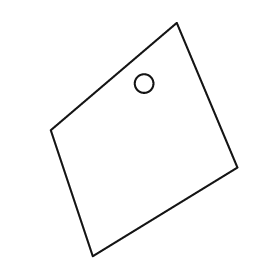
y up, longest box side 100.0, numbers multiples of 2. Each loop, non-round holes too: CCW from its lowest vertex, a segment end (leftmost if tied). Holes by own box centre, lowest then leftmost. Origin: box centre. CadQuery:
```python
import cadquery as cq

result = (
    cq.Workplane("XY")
    .moveTo(-22.0, -50.0)
    .lineTo(40.0, -12.0)
    .lineTo(14.0, 50.0)
    .lineTo(-40.0, 4.0)
    .close()
    .moveTo(0.0, 24.0)
    .circle(4.0)
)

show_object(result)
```